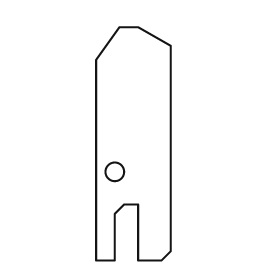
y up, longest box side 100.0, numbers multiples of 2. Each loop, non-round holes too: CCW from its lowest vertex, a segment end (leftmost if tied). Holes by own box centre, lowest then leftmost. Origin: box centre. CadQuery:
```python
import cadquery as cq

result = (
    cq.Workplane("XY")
    .moveTo(-16.0, -50.0)
    .lineTo(-8.0, -50.0)
    .lineTo(-8.0, -30.0)
    .lineTo(-4.0, -26.0)
    .lineTo(2.0, -26.0)
    .lineTo(2.0, -50.0)
    .lineTo(12.0, -50.0)
    .lineTo(16.0, -46.0)
    .lineTo(16.0, 42.0)
    .lineTo(2.0, 50.0)
    .lineTo(-6.0, 50.0)
    .lineTo(-16.0, 36.0)
    .close()
    .moveTo(-8.0, -12.0)
    .circle(4.0)
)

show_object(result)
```